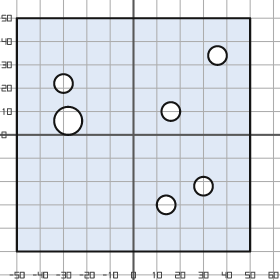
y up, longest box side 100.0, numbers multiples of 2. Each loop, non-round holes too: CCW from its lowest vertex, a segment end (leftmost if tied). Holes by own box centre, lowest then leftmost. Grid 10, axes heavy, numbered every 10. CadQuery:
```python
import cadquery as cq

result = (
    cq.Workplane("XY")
    .moveTo(-50.0, -50.0)
    .lineTo(50.0, -50.0)
    .lineTo(50.0, 50.0)
    .lineTo(-50.0, 50.0)
    .close()
    .moveTo(14.0, -30.0)
    .circle(4.0)
    .moveTo(30.0, -22.0)
    .circle(4.0)
    .moveTo(-28.0, 6.0)
    .circle(6.0)
    .moveTo(16.0, 10.0)
    .circle(4.0)
    .moveTo(-30.0, 22.0)
    .circle(4.0)
    .moveTo(36.0, 34.0)
    .circle(4.0)
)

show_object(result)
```